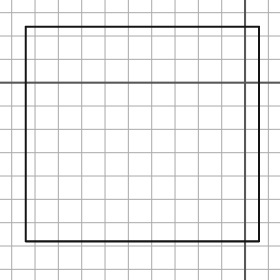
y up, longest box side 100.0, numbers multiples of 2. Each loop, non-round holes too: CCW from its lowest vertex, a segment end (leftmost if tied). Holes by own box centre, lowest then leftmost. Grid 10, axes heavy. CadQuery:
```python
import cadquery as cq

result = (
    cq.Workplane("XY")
    .moveTo(-94.0, -68.0)
    .lineTo(6.0, -68.0)
    .lineTo(6.0, 24.0)
    .lineTo(-94.0, 24.0)
    .close()
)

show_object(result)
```